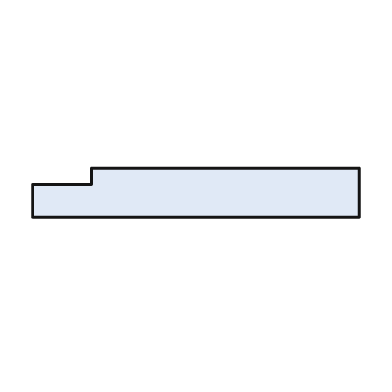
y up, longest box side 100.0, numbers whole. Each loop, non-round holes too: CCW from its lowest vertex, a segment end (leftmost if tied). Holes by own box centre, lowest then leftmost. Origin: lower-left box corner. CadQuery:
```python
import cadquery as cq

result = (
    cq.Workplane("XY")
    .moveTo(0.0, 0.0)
    .lineTo(100.0, 0.0)
    .lineTo(100.0, 15.0)
    .lineTo(18.0, 15.0)
    .lineTo(18.0, 10.0)
    .lineTo(0.0, 10.0)
    .close()
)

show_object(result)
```